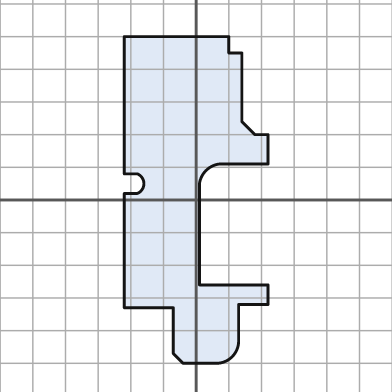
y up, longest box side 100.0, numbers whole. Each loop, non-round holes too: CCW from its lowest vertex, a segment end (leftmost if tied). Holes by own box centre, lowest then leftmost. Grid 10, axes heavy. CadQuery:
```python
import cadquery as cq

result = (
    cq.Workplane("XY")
    .moveTo(-4.0, -50.0)
    .lineTo(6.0, -50.0)
    .threePointArc((11.0, -48.0), (13.0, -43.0))
    .lineTo(13.0, -32.0)
    .lineTo(22.0, -32.0)
    .lineTo(22.0, -26.0)
    .lineTo(1.0, -26.0)
    .lineTo(1.0, 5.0)
    .threePointArc((3.0, 9.0), (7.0, 11.0))
    .lineTo(22.0, 11.0)
    .lineTo(22.0, 20.0)
    .lineTo(18.0, 20.0)
    .lineTo(14.0, 24.0)
    .lineTo(14.0, 45.0)
    .lineTo(10.0, 45.0)
    .lineTo(10.0, 50.0)
    .lineTo(-22.0, 50.0)
    .lineTo(-22.0, 8.0)
    .lineTo(-18.0, 8.0)
    .threePointArc((-16.0, 5.0), (-18.0, 2.0))
    .lineTo(-22.0, 2.0)
    .lineTo(-22.0, -33.0)
    .lineTo(-7.0, -33.0)
    .lineTo(-7.0, -47.0)
    .close()
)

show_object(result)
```